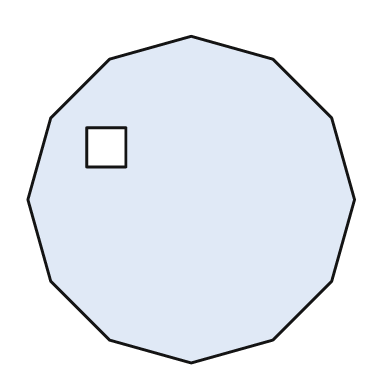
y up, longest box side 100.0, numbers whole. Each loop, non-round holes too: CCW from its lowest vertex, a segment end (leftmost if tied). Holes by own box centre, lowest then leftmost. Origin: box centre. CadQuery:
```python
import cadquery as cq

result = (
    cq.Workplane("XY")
    .moveTo(0.0, -50.0)
    .lineTo(25.0, -43.0)
    .lineTo(43.0, -25.0)
    .lineTo(50.0, 0.0)
    .lineTo(43.0, 25.0)
    .lineTo(25.0, 43.0)
    .lineTo(0.0, 50.0)
    .lineTo(-25.0, 43.0)
    .lineTo(-43.0, 25.0)
    .lineTo(-50.0, 0.0)
    .lineTo(-43.0, -25.0)
    .lineTo(-25.0, -43.0)
    .close()
    .moveTo(-32.0, 10.0)
    .lineTo(-20.0, 10.0)
    .lineTo(-20.0, 22.0)
    .lineTo(-32.0, 22.0)
    .close()
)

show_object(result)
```